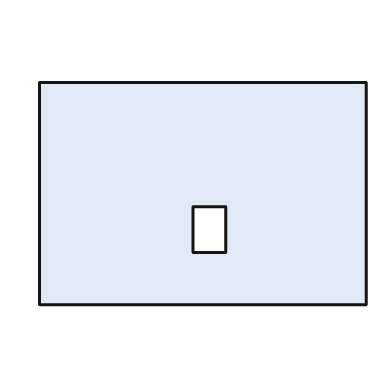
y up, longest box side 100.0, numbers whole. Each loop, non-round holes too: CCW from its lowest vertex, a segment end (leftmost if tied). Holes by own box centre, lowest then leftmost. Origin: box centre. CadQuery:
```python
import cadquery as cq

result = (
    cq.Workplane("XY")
    .moveTo(-50.0, -34.0)
    .lineTo(50.0, -34.0)
    .lineTo(50.0, 34.0)
    .lineTo(-50.0, 34.0)
    .close()
    .moveTo(-3.0, -18.0)
    .lineTo(7.0, -18.0)
    .lineTo(7.0, -4.0)
    .lineTo(-3.0, -4.0)
    .close()
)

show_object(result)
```